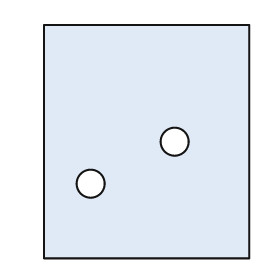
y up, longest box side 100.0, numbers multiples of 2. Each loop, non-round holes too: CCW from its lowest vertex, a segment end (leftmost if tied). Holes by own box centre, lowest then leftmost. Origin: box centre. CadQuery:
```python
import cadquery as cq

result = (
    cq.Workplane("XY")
    .moveTo(-44.0, -50.0)
    .lineTo(44.0, -50.0)
    .lineTo(44.0, 50.0)
    .lineTo(-44.0, 50.0)
    .close()
    .moveTo(-24.0, -18.0)
    .circle(6.0)
    .moveTo(12.0, 0.0)
    .circle(6.0)
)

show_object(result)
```